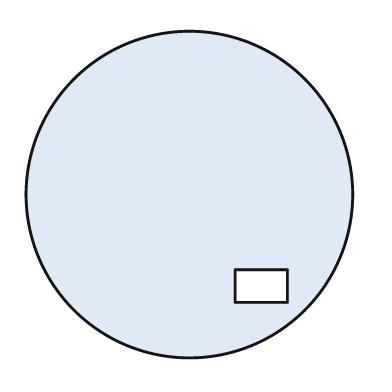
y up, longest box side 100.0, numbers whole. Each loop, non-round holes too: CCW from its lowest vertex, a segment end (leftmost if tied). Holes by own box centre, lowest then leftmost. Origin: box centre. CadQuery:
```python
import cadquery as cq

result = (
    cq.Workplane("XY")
    .moveTo(0.0, 0.0)
    .circle(50.0)
    .moveTo(14.0, -33.0)
    .lineTo(30.0, -33.0)
    .lineTo(30.0, -23.0)
    .lineTo(14.0, -23.0)
    .close()
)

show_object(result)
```